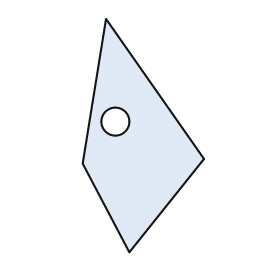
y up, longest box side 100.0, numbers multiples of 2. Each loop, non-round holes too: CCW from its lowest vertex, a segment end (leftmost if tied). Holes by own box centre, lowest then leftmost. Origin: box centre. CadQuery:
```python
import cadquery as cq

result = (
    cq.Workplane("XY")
    .moveTo(-6.0, -50.0)
    .lineTo(26.0, -10.0)
    .lineTo(-16.0, 50.0)
    .lineTo(-26.0, -12.0)
    .close()
    .moveTo(-12.0, 6.0)
    .circle(6.0)
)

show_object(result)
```